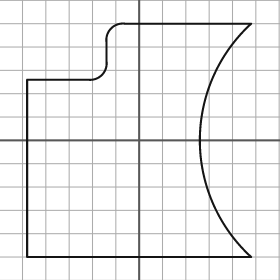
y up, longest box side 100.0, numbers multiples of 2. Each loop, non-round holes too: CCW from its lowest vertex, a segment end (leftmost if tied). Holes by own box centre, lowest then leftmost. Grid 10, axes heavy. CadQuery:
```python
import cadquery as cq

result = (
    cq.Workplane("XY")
    .moveTo(-48.0, -50.0)
    .lineTo(48.0, -50.0)
    .threePointArc((26.0, 0.0), (48.0, 50.0))
    .lineTo(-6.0, 50.0)
    .threePointArc((-12.0, 48.0), (-14.0, 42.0))
    .lineTo(-14.0, 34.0)
    .threePointArc((-16.0, 28.0), (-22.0, 26.0))
    .lineTo(-48.0, 26.0)
    .close()
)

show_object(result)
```